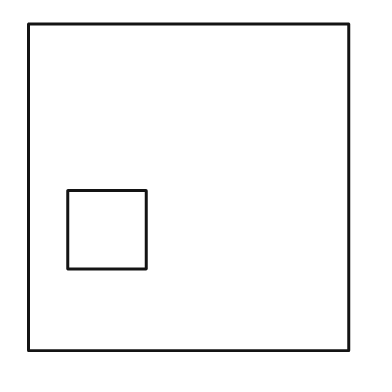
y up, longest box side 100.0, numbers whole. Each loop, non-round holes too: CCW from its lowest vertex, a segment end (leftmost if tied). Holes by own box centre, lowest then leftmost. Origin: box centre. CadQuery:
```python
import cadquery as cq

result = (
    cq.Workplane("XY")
    .moveTo(-49.0, -50.0)
    .lineTo(49.0, -50.0)
    .lineTo(49.0, 50.0)
    .lineTo(-49.0, 50.0)
    .close()
    .moveTo(-37.0, -25.0)
    .lineTo(-13.0, -25.0)
    .lineTo(-13.0, -1.0)
    .lineTo(-37.0, -1.0)
    .close()
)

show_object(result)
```